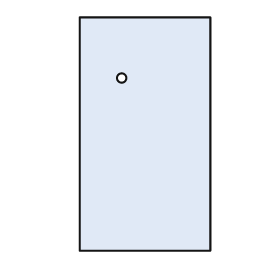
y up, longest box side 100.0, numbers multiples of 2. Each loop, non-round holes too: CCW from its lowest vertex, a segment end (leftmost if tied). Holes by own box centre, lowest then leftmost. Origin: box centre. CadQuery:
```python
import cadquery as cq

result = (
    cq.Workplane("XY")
    .moveTo(-28.0, -50.0)
    .lineTo(28.0, -50.0)
    .lineTo(28.0, 50.0)
    .lineTo(-28.0, 50.0)
    .close()
    .moveTo(-10.0, 24.0)
    .circle(2.0)
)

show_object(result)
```